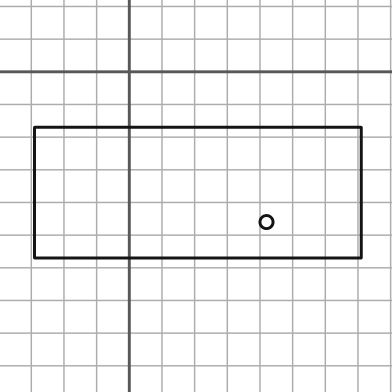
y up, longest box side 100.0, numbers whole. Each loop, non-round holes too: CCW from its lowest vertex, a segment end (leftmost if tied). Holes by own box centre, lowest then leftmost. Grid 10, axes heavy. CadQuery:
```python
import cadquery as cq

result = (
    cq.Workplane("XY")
    .moveTo(-29.0, -57.0)
    .lineTo(71.0, -57.0)
    .lineTo(71.0, -17.0)
    .lineTo(-29.0, -17.0)
    .close()
    .moveTo(42.0, -46.0)
    .circle(2.0)
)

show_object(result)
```